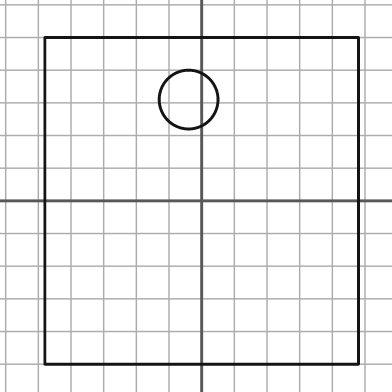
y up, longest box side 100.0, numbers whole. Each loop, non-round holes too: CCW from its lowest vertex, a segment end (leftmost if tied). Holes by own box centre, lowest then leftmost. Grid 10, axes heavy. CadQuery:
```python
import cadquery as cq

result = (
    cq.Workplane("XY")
    .moveTo(-48.0, -50.0)
    .lineTo(48.0, -50.0)
    .lineTo(48.0, 50.0)
    .lineTo(-48.0, 50.0)
    .close()
    .moveTo(-4.0, 31.0)
    .circle(9.0)
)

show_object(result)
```